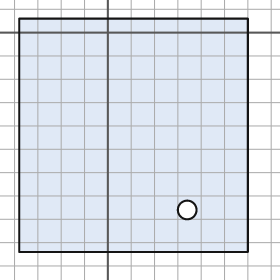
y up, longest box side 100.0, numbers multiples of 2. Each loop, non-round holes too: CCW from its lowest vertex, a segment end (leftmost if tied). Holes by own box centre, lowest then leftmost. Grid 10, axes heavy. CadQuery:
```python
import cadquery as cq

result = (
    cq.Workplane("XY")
    .moveTo(-38.0, -94.0)
    .lineTo(60.0, -94.0)
    .lineTo(60.0, 6.0)
    .lineTo(-38.0, 6.0)
    .close()
    .moveTo(34.0, -76.0)
    .circle(4.0)
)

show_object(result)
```